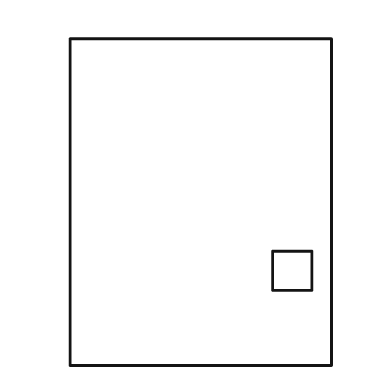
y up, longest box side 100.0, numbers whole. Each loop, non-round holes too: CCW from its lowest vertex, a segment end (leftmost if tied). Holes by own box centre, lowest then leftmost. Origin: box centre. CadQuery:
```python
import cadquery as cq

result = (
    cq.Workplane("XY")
    .moveTo(-40.0, -50.0)
    .lineTo(40.0, -50.0)
    .lineTo(40.0, 50.0)
    .lineTo(-40.0, 50.0)
    .close()
    .moveTo(22.0, -27.0)
    .lineTo(34.0, -27.0)
    .lineTo(34.0, -15.0)
    .lineTo(22.0, -15.0)
    .close()
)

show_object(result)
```